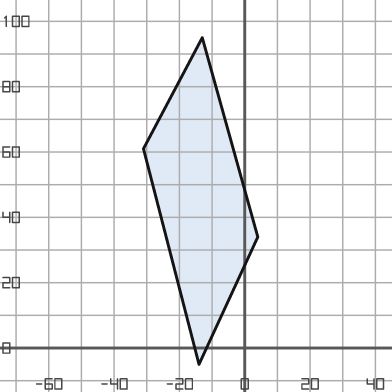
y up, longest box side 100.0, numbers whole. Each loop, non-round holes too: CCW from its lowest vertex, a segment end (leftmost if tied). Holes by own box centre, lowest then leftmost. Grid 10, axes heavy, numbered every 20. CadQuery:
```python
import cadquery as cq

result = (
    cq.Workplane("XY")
    .moveTo(-14.0, -5.0)
    .lineTo(4.0, 34.0)
    .lineTo(-13.0, 95.0)
    .lineTo(-31.0, 61.0)
    .close()
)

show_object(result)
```